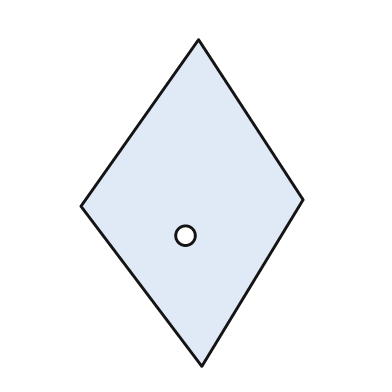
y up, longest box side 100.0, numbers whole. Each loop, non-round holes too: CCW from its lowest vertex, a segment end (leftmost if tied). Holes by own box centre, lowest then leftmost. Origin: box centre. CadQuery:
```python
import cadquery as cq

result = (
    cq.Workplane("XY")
    .moveTo(3.0, -50.0)
    .lineTo(34.0, 1.0)
    .lineTo(2.0, 50.0)
    .lineTo(-34.0, -1.0)
    .close()
    .moveTo(-2.0, -10.0)
    .circle(3.0)
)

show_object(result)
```